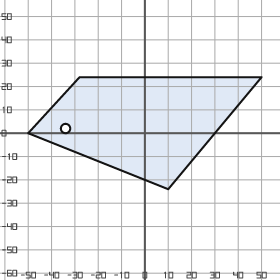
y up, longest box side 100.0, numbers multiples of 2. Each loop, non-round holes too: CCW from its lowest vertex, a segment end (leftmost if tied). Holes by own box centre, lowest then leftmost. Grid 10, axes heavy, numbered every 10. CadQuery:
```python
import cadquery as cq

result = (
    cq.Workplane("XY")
    .moveTo(10.0, -24.0)
    .lineTo(50.0, 24.0)
    .lineTo(-28.0, 24.0)
    .lineTo(-50.0, 0.0)
    .close()
    .moveTo(-34.0, 2.0)
    .circle(2.0)
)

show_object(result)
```